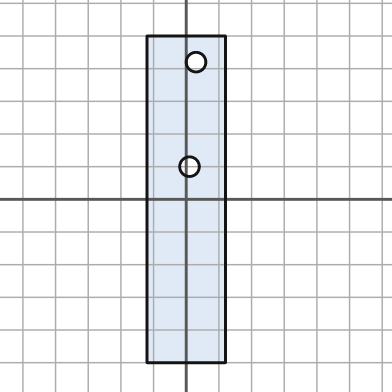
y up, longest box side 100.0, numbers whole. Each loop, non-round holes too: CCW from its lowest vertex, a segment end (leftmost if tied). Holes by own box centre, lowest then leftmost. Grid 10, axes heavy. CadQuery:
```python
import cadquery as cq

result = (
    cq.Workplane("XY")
    .moveTo(-12.0, -50.0)
    .lineTo(12.0, -50.0)
    .lineTo(12.0, 50.0)
    .lineTo(-12.0, 50.0)
    .close()
    .moveTo(1.0, 10.0)
    .circle(3.0)
    .moveTo(3.0, 42.0)
    .circle(3.0)
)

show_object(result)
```